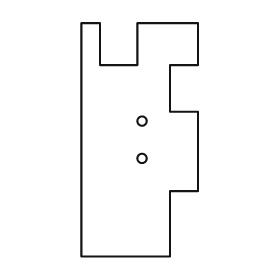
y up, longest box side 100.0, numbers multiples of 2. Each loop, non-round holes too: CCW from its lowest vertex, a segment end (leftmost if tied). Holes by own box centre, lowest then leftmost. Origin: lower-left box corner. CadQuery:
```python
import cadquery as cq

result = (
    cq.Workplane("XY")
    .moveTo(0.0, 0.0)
    .lineTo(38.0, 0.0)
    .lineTo(38.0, 28.0)
    .lineTo(50.0, 28.0)
    .lineTo(50.0, 62.0)
    .lineTo(38.0, 62.0)
    .lineTo(38.0, 82.0)
    .lineTo(50.0, 82.0)
    .lineTo(50.0, 100.0)
    .lineTo(24.0, 100.0)
    .lineTo(24.0, 82.0)
    .lineTo(8.0, 82.0)
    .lineTo(8.0, 100.0)
    .lineTo(0.0, 100.0)
    .close()
    .moveTo(26.0, 42.0)
    .circle(2.0)
    .moveTo(26.0, 58.0)
    .circle(2.0)
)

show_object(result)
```